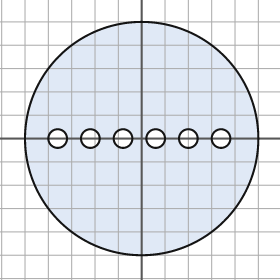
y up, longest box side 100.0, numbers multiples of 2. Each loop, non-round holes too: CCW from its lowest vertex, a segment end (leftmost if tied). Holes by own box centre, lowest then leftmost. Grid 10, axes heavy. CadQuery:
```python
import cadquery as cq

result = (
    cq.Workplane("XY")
    .moveTo(0.0, 0.0)
    .circle(50.0)
    .moveTo(-36.0, 0.0)
    .circle(4.0)
    .moveTo(-22.0, 0.0)
    .circle(4.0)
    .moveTo(-8.0, 0.0)
    .circle(4.0)
    .moveTo(6.0, 0.0)
    .circle(4.0)
    .moveTo(20.0, 0.0)
    .circle(4.0)
    .moveTo(34.0, 0.0)
    .circle(4.0)
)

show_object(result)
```